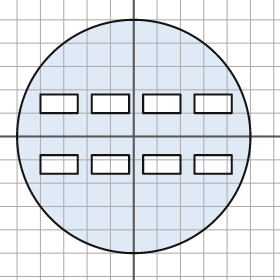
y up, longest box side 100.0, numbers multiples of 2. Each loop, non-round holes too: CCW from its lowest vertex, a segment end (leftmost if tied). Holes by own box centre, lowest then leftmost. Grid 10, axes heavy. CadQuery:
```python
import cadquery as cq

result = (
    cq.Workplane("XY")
    .moveTo(0.0, 0.0)
    .circle(50.0)
    .moveTo(-40.0, -16.0)
    .lineTo(-24.0, -16.0)
    .lineTo(-24.0, -8.0)
    .lineTo(-40.0, -8.0)
    .close()
    .moveTo(-18.0, -16.0)
    .lineTo(-2.0, -16.0)
    .lineTo(-2.0, -8.0)
    .lineTo(-18.0, -8.0)
    .close()
    .moveTo(4.0, -16.0)
    .lineTo(20.0, -16.0)
    .lineTo(20.0, -8.0)
    .lineTo(4.0, -8.0)
    .close()
    .moveTo(26.0, -16.0)
    .lineTo(42.0, -16.0)
    .lineTo(42.0, -8.0)
    .lineTo(26.0, -8.0)
    .close()
    .moveTo(-40.0, 10.0)
    .lineTo(-24.0, 10.0)
    .lineTo(-24.0, 18.0)
    .lineTo(-40.0, 18.0)
    .close()
    .moveTo(-18.0, 10.0)
    .lineTo(-2.0, 10.0)
    .lineTo(-2.0, 18.0)
    .lineTo(-18.0, 18.0)
    .close()
    .moveTo(4.0, 10.0)
    .lineTo(20.0, 10.0)
    .lineTo(20.0, 18.0)
    .lineTo(4.0, 18.0)
    .close()
    .moveTo(26.0, 10.0)
    .lineTo(42.0, 10.0)
    .lineTo(42.0, 18.0)
    .lineTo(26.0, 18.0)
    .close()
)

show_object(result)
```